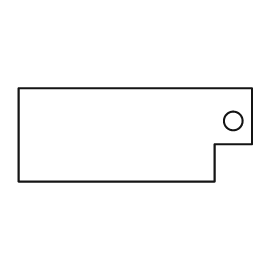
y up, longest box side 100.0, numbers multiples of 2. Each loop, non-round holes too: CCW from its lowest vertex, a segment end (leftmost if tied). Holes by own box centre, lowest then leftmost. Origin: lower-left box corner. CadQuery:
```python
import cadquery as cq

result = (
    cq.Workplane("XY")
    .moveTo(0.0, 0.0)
    .lineTo(84.0, 0.0)
    .lineTo(84.0, 16.0)
    .lineTo(100.0, 16.0)
    .lineTo(100.0, 40.0)
    .lineTo(0.0, 40.0)
    .close()
    .moveTo(92.0, 26.0)
    .circle(4.0)
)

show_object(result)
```